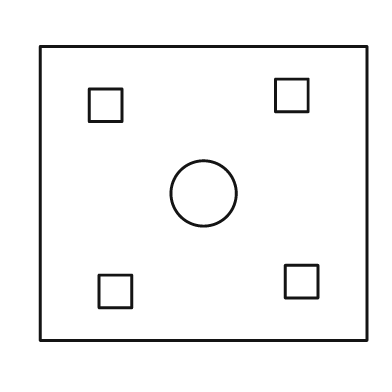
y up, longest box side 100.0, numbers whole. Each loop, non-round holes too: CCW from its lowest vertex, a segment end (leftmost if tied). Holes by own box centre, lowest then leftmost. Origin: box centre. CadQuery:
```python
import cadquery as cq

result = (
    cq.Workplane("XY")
    .moveTo(-50.0, -45.0)
    .lineTo(50.0, -45.0)
    .lineTo(50.0, 45.0)
    .lineTo(-50.0, 45.0)
    .close()
    .moveTo(-32.0, -35.0)
    .lineTo(-22.0, -35.0)
    .lineTo(-22.0, -25.0)
    .lineTo(-32.0, -25.0)
    .close()
    .moveTo(25.0, -32.0)
    .lineTo(35.0, -32.0)
    .lineTo(35.0, -22.0)
    .lineTo(25.0, -22.0)
    .close()
    .moveTo(0.0, 0.0)
    .circle(10.0)
    .moveTo(-35.0, 22.0)
    .lineTo(-25.0, 22.0)
    .lineTo(-25.0, 32.0)
    .lineTo(-35.0, 32.0)
    .close()
    .moveTo(22.0, 25.0)
    .lineTo(32.0, 25.0)
    .lineTo(32.0, 35.0)
    .lineTo(22.0, 35.0)
    .close()
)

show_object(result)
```